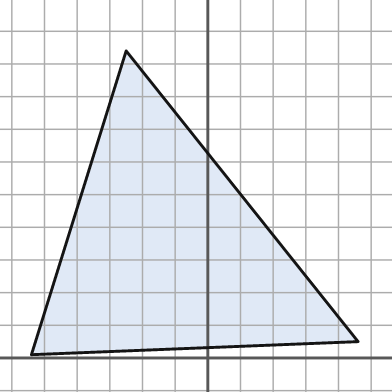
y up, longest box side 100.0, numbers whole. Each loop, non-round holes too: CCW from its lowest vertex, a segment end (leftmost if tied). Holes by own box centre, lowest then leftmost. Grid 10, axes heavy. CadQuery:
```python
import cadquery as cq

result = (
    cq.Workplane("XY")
    .moveTo(-54.0, 1.0)
    .lineTo(46.0, 5.0)
    .lineTo(-25.0, 94.0)
    .close()
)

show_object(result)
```